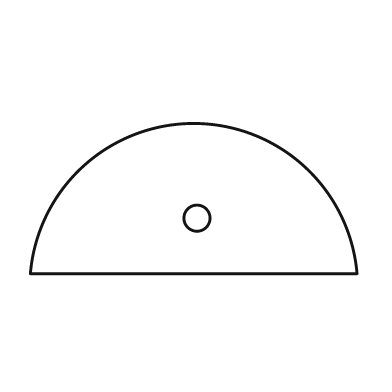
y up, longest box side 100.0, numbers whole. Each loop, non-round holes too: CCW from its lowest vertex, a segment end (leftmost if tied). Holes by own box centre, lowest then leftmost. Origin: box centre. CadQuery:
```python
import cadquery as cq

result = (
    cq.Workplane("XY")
    .moveTo(-50.0, -23.0)
    .lineTo(50.0, -23.0)
    .threePointArc((0.0, 23.0), (-50.0, -23.0))
    .close()
    .moveTo(1.0, -6.0)
    .circle(4.0)
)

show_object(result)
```